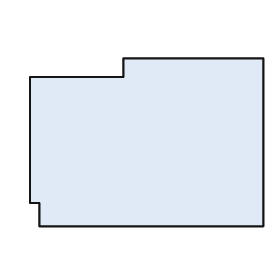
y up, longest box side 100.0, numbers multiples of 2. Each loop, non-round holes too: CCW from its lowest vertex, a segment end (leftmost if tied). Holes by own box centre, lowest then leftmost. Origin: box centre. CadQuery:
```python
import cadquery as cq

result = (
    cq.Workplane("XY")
    .moveTo(-46.0, -36.0)
    .lineTo(50.0, -36.0)
    .lineTo(50.0, 36.0)
    .lineTo(-10.0, 36.0)
    .lineTo(-10.0, 28.0)
    .lineTo(-50.0, 28.0)
    .lineTo(-50.0, -26.0)
    .lineTo(-46.0, -26.0)
    .close()
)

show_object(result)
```